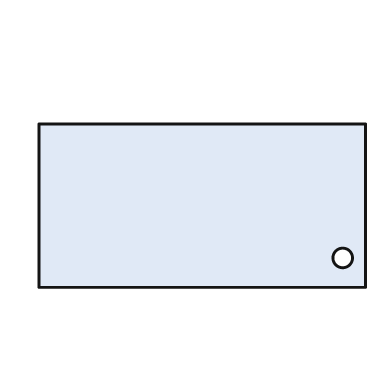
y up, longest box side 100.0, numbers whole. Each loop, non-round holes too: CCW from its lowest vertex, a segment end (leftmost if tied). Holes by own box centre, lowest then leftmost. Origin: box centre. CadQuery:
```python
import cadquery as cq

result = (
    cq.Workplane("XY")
    .moveTo(-50.0, -25.0)
    .lineTo(50.0, -25.0)
    .lineTo(50.0, 25.0)
    .lineTo(-50.0, 25.0)
    .close()
    .moveTo(43.0, -16.0)
    .circle(3.0)
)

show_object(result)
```